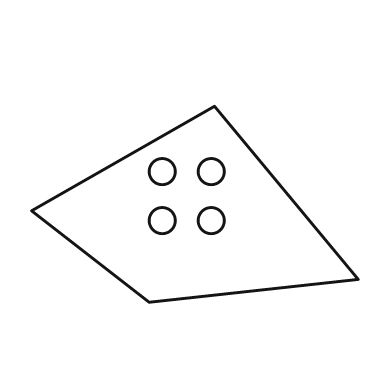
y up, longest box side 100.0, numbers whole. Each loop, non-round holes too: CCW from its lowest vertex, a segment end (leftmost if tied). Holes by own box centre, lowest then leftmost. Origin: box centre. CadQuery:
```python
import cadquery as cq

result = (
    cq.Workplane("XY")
    .moveTo(-14.0, -30.0)
    .lineTo(50.0, -23.0)
    .lineTo(6.0, 30.0)
    .lineTo(-50.0, -2.0)
    .close()
    .moveTo(-10.0, -5.0)
    .circle(4.0)
    .moveTo(5.0, -5.0)
    .circle(4.0)
    .moveTo(-10.0, 10.0)
    .circle(4.0)
    .moveTo(5.0, 10.0)
    .circle(4.0)
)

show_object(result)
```